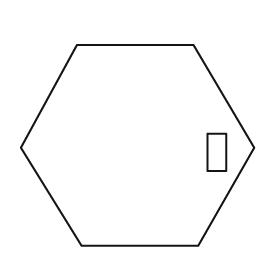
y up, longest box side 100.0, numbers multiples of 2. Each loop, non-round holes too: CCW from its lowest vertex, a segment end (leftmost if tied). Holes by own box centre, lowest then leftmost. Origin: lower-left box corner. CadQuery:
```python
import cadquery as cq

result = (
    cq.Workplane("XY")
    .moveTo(26.0, 0.0)
    .lineTo(76.0, 0.0)
    .lineTo(100.0, 42.0)
    .lineTo(74.0, 86.0)
    .lineTo(24.0, 86.0)
    .lineTo(0.0, 42.0)
    .close()
    .moveTo(80.0, 32.0)
    .lineTo(88.0, 32.0)
    .lineTo(88.0, 48.0)
    .lineTo(80.0, 48.0)
    .close()
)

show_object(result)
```